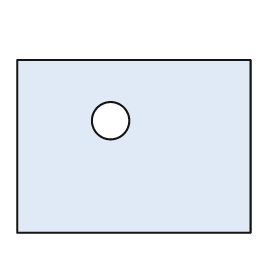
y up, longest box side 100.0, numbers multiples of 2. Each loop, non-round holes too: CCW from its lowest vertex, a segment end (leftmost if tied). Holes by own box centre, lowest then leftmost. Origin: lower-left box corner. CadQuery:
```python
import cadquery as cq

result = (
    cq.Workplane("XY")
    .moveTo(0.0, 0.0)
    .lineTo(100.0, 0.0)
    .lineTo(100.0, 74.0)
    .lineTo(0.0, 74.0)
    .close()
    .moveTo(40.0, 48.0)
    .circle(8.0)
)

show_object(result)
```